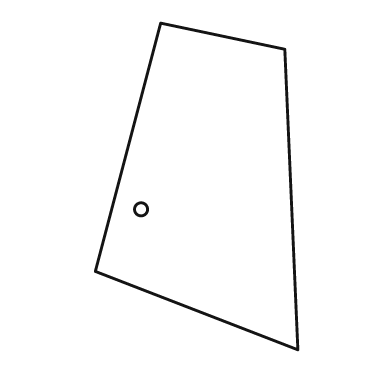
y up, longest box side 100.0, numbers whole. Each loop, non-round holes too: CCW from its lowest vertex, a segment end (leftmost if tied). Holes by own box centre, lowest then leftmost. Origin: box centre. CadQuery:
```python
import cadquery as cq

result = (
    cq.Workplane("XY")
    .moveTo(31.0, -50.0)
    .lineTo(27.0, 42.0)
    .lineTo(-11.0, 50.0)
    .lineTo(-31.0, -26.0)
    .close()
    .moveTo(-17.0, -7.0)
    .circle(2.0)
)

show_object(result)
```